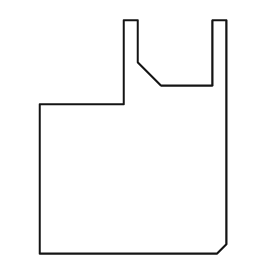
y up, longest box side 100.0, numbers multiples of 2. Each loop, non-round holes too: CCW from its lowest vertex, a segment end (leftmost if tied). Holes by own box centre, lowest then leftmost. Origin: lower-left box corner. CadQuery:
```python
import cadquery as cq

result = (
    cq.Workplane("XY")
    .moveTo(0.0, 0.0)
    .lineTo(76.0, 0.0)
    .lineTo(80.0, 4.0)
    .lineTo(80.0, 100.0)
    .lineTo(74.0, 100.0)
    .lineTo(74.0, 72.0)
    .lineTo(52.0, 72.0)
    .lineTo(42.0, 82.0)
    .lineTo(42.0, 100.0)
    .lineTo(36.0, 100.0)
    .lineTo(36.0, 64.0)
    .lineTo(0.0, 64.0)
    .close()
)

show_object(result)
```